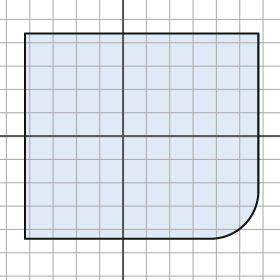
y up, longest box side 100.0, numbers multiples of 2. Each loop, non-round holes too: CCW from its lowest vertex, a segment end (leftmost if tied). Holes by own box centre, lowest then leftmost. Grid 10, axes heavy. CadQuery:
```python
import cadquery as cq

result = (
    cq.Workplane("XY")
    .moveTo(-42.0, -44.0)
    .lineTo(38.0, -44.0)
    .threePointArc((52.0, -38.0), (58.0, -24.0))
    .lineTo(58.0, 44.0)
    .lineTo(-42.0, 44.0)
    .close()
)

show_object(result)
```